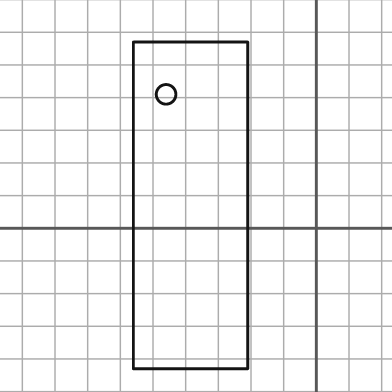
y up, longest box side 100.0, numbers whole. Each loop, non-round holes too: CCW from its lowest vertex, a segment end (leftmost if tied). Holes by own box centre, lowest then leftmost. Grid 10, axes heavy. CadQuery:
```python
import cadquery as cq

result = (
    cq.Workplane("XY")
    .moveTo(-56.0, -43.0)
    .lineTo(-21.0, -43.0)
    .lineTo(-21.0, 57.0)
    .lineTo(-56.0, 57.0)
    .close()
    .moveTo(-46.0, 41.0)
    .circle(3.0)
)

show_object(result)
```